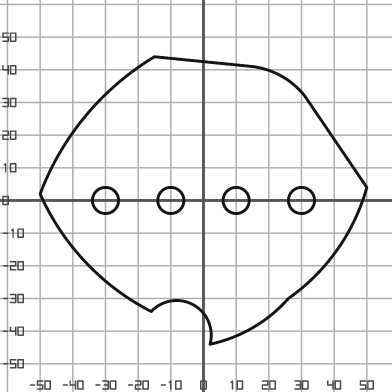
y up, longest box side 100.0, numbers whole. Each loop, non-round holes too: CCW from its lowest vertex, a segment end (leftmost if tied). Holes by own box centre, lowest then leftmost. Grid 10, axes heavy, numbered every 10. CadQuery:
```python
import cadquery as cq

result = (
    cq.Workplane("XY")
    .moveTo(2.0, -44.0)
    .threePointArc((15.0, -39.0), (26.0, -30.0))
    .threePointArc((41.0, -15.0), (50.0, 4.0))
    .lineTo(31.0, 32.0)
    .threePointArc((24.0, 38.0), (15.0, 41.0))
    .lineTo(-15.0, 44.0)
    .threePointArc((-36.0, 26.0), (-50.0, 2.0))
    .threePointArc((-36.0, -19.0), (-16.0, -34.0))
    .threePointArc((-3.0, -32.0), (2.0, -44.0))
    .close()
    .moveTo(-30.0, 0.0)
    .circle(4.0)
    .moveTo(-10.0, 0.0)
    .circle(4.0)
    .moveTo(10.0, 0.0)
    .circle(4.0)
    .moveTo(30.0, 0.0)
    .circle(4.0)
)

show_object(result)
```